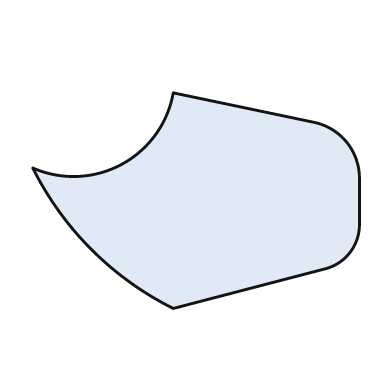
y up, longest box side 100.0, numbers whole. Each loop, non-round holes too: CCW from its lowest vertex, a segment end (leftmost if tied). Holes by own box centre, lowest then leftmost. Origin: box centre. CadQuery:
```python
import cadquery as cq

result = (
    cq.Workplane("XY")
    .moveTo(-7.0, -33.0)
    .lineTo(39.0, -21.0)
    .threePointArc((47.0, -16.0), (50.0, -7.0))
    .lineTo(50.0, 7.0)
    .threePointArc((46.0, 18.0), (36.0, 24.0))
    .lineTo(-7.0, 33.0)
    .threePointArc((-23.0, 11.0), (-50.0, 10.0))
    .threePointArc((-32.0, -15.0), (-7.0, -33.0))
    .close()
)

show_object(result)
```